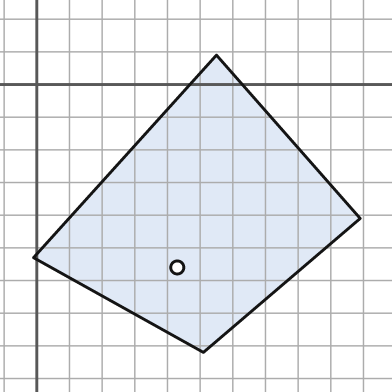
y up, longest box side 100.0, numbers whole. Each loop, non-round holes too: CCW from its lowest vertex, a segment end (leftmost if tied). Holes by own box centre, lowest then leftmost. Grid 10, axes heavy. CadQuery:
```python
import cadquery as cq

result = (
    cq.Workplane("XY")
    .moveTo(51.0, -82.0)
    .lineTo(99.0, -41.0)
    .lineTo(55.0, 9.0)
    .lineTo(-1.0, -53.0)
    .close()
    .moveTo(43.0, -56.0)
    .circle(2.0)
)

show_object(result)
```